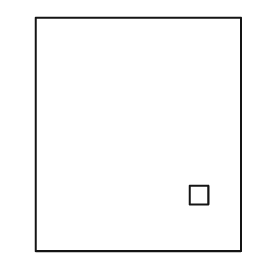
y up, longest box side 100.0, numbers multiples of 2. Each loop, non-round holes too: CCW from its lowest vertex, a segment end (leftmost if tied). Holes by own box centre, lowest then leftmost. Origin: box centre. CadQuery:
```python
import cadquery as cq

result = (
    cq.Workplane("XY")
    .moveTo(-44.0, -50.0)
    .lineTo(44.0, -50.0)
    .lineTo(44.0, 50.0)
    .lineTo(-44.0, 50.0)
    .close()
    .moveTo(22.0, -30.0)
    .lineTo(30.0, -30.0)
    .lineTo(30.0, -22.0)
    .lineTo(22.0, -22.0)
    .close()
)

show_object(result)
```